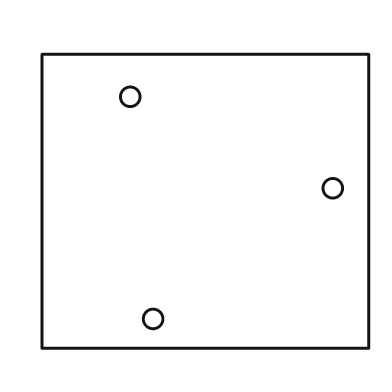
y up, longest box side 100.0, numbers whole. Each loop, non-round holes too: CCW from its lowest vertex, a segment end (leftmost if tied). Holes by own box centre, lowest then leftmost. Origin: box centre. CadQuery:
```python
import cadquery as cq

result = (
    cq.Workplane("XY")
    .moveTo(-50.0, -45.0)
    .lineTo(50.0, -45.0)
    .lineTo(50.0, 45.0)
    .lineTo(-50.0, 45.0)
    .close()
    .moveTo(-16.0, -36.0)
    .circle(3.0)
    .moveTo(39.0, 4.0)
    .circle(3.0)
    .moveTo(-23.0, 32.0)
    .circle(3.0)
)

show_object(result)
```